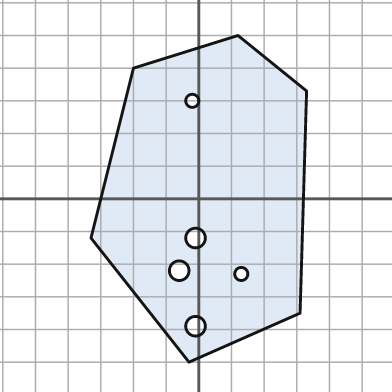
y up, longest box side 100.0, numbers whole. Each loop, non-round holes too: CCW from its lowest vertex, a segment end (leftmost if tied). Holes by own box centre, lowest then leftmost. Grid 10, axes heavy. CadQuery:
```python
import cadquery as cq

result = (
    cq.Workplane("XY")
    .moveTo(-3.0, -50.0)
    .lineTo(31.0, -35.0)
    .lineTo(33.0, 33.0)
    .lineTo(12.0, 50.0)
    .lineTo(-20.0, 40.0)
    .lineTo(-33.0, -12.0)
    .close()
    .moveTo(-1.0, -39.0)
    .circle(3.0)
    .moveTo(13.0, -23.0)
    .circle(2.0)
    .moveTo(-6.0, -22.0)
    .circle(3.0)
    .moveTo(-1.0, -12.0)
    .circle(3.0)
    .moveTo(-2.0, 30.0)
    .circle(2.0)
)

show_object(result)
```